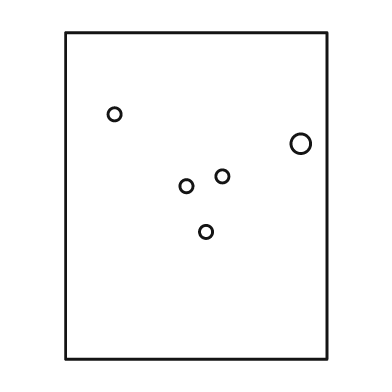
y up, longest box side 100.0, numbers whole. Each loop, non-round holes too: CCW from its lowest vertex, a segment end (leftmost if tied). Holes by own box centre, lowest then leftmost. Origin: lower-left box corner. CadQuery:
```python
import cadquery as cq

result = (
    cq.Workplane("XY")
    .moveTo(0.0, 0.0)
    .lineTo(80.0, 0.0)
    .lineTo(80.0, 100.0)
    .lineTo(0.0, 100.0)
    .close()
    .moveTo(43.0, 39.0)
    .circle(2.0)
    .moveTo(37.0, 53.0)
    .circle(2.0)
    .moveTo(48.0, 56.0)
    .circle(2.0)
    .moveTo(72.0, 66.0)
    .circle(3.0)
    .moveTo(15.0, 75.0)
    .circle(2.0)
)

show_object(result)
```